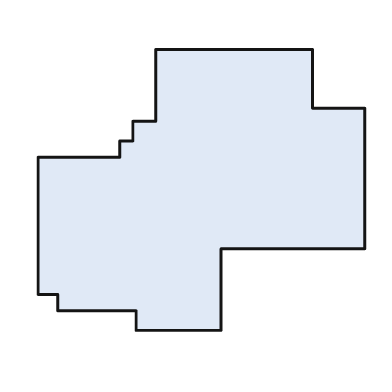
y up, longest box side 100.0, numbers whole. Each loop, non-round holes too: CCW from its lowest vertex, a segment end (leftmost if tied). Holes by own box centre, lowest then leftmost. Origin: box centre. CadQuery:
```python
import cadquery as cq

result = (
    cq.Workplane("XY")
    .moveTo(-20.0, -43.0)
    .lineTo(6.0, -43.0)
    .lineTo(6.0, -18.0)
    .lineTo(50.0, -18.0)
    .lineTo(50.0, 25.0)
    .lineTo(34.0, 25.0)
    .lineTo(34.0, 43.0)
    .lineTo(-14.0, 43.0)
    .lineTo(-14.0, 21.0)
    .lineTo(-21.0, 21.0)
    .lineTo(-21.0, 15.0)
    .lineTo(-25.0, 15.0)
    .lineTo(-25.0, 10.0)
    .lineTo(-50.0, 10.0)
    .lineTo(-50.0, -32.0)
    .lineTo(-44.0, -32.0)
    .lineTo(-44.0, -37.0)
    .lineTo(-20.0, -37.0)
    .close()
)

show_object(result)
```